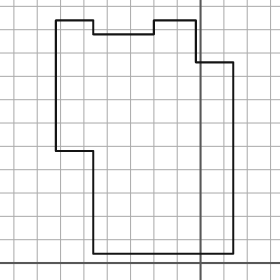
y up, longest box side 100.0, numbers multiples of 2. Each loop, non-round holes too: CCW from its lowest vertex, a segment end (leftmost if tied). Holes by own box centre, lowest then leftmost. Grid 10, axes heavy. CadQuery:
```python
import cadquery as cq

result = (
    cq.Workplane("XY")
    .moveTo(-46.0, 4.0)
    .lineTo(14.0, 4.0)
    .lineTo(14.0, 86.0)
    .lineTo(-2.0, 86.0)
    .lineTo(-2.0, 104.0)
    .lineTo(-20.0, 104.0)
    .lineTo(-20.0, 98.0)
    .lineTo(-46.0, 98.0)
    .lineTo(-46.0, 104.0)
    .lineTo(-62.0, 104.0)
    .lineTo(-62.0, 48.0)
    .lineTo(-46.0, 48.0)
    .close()
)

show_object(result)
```